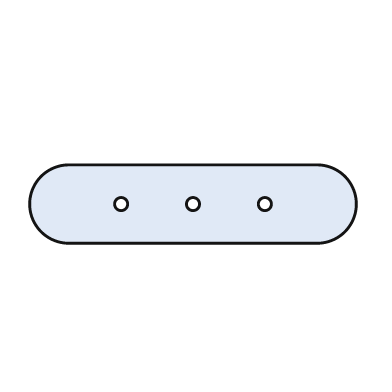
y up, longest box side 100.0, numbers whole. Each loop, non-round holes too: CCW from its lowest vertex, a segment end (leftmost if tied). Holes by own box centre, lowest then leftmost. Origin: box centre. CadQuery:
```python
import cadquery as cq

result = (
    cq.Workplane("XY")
    .moveTo(-38.0, -12.0)
    .lineTo(38.0, -12.0)
    .threePointArc((50.0, 0.0), (38.0, 12.0))
    .lineTo(-38.0, 12.0)
    .threePointArc((-50.0, 0.0), (-38.0, -12.0))
    .close()
    .moveTo(-22.0, 0.0)
    .circle(2.0)
    .moveTo(0.0, 0.0)
    .circle(2.0)
    .moveTo(22.0, 0.0)
    .circle(2.0)
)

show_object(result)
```